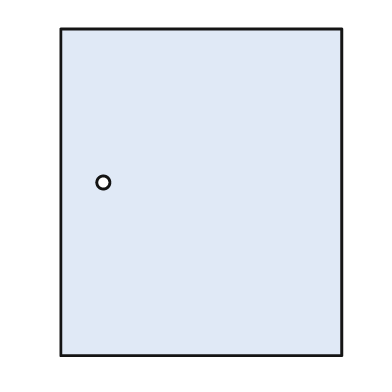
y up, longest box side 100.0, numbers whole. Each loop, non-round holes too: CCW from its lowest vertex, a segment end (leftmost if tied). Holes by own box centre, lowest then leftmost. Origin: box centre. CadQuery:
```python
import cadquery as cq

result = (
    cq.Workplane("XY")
    .moveTo(-43.0, -50.0)
    .lineTo(43.0, -50.0)
    .lineTo(43.0, 50.0)
    .lineTo(-43.0, 50.0)
    .close()
    .moveTo(-30.0, 3.0)
    .circle(2.0)
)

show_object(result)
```